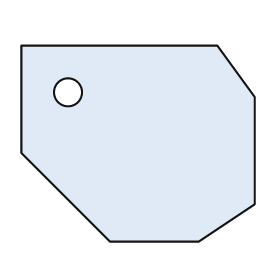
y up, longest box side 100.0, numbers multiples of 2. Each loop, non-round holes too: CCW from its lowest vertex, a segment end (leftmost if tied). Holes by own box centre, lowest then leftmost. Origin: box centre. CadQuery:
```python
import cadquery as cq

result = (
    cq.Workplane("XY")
    .moveTo(-12.0, -42.0)
    .lineTo(26.0, -42.0)
    .lineTo(50.0, -26.0)
    .lineTo(50.0, 20.0)
    .lineTo(34.0, 42.0)
    .lineTo(-50.0, 42.0)
    .lineTo(-50.0, -4.0)
    .close()
    .moveTo(-30.0, 22.0)
    .circle(6.0)
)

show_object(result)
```